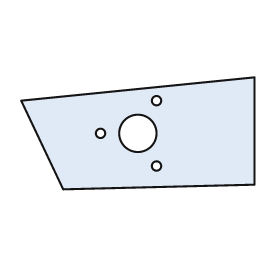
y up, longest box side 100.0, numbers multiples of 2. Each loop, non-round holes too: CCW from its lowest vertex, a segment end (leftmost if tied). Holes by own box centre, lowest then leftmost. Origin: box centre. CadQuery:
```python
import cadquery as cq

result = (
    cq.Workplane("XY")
    .moveTo(-32.0, -24.0)
    .lineTo(50.0, -22.0)
    .lineTo(50.0, 24.0)
    .lineTo(-50.0, 14.0)
    .close()
    .moveTo(8.0, -14.0)
    .circle(2.0)
    .moveTo(-16.0, 0.0)
    .circle(2.0)
    .moveTo(0.0, 0.0)
    .circle(8.0)
    .moveTo(8.0, 14.0)
    .circle(2.0)
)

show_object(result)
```